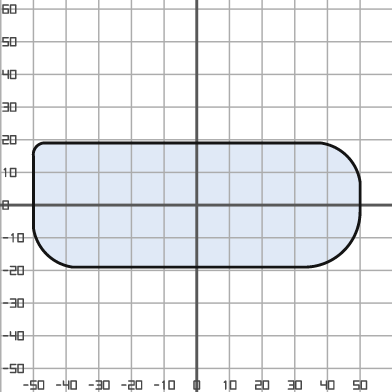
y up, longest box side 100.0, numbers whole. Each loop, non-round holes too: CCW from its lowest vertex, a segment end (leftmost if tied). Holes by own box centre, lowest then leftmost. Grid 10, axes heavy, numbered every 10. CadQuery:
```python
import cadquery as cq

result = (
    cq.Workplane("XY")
    .moveTo(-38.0, -19.0)
    .lineTo(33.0, -19.0)
    .threePointArc((45.0, -14.0), (50.0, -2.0))
    .lineTo(50.0, 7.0)
    .threePointArc((46.0, 15.0), (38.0, 19.0))
    .lineTo(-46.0, 19.0)
    .threePointArc((-49.0, 18.0), (-50.0, 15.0))
    .lineTo(-50.0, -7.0)
    .threePointArc((-46.0, -15.0), (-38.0, -19.0))
    .close()
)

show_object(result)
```